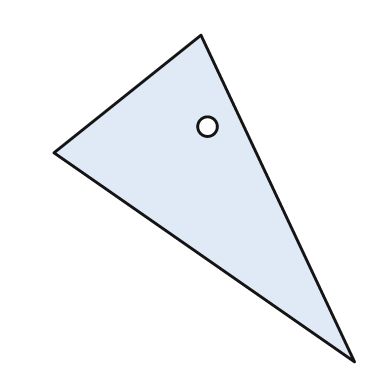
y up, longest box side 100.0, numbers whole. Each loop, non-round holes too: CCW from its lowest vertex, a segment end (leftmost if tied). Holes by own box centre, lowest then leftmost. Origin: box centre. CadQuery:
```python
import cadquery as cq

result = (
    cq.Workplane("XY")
    .moveTo(46.0, -50.0)
    .lineTo(-1.0, 50.0)
    .lineTo(-46.0, 14.0)
    .close()
    .moveTo(1.0, 22.0)
    .circle(3.0)
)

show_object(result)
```